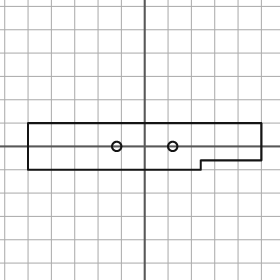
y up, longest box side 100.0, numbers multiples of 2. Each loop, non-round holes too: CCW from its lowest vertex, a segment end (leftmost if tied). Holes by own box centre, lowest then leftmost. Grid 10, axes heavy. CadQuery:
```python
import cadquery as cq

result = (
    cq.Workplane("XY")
    .moveTo(-50.0, -10.0)
    .lineTo(24.0, -10.0)
    .lineTo(24.0, -6.0)
    .lineTo(50.0, -6.0)
    .lineTo(50.0, 10.0)
    .lineTo(-50.0, 10.0)
    .close()
    .moveTo(-12.0, 0.0)
    .circle(2.0)
    .moveTo(12.0, 0.0)
    .circle(2.0)
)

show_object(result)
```